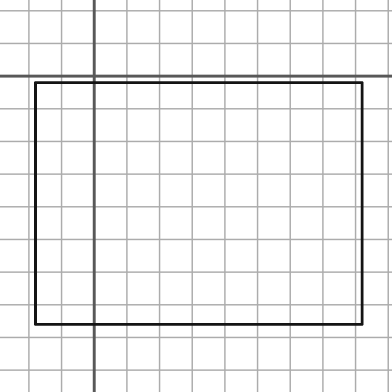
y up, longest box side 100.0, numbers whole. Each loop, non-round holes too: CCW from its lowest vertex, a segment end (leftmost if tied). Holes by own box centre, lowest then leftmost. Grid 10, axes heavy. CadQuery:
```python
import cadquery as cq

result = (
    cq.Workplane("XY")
    .moveTo(-18.0, -76.0)
    .lineTo(82.0, -76.0)
    .lineTo(82.0, -2.0)
    .lineTo(-18.0, -2.0)
    .close()
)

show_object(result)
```